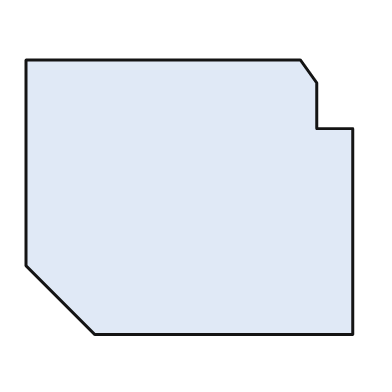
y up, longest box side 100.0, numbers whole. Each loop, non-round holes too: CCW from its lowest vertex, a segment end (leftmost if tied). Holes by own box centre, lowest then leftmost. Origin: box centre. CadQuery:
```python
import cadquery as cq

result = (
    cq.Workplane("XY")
    .moveTo(-29.0, -42.0)
    .lineTo(50.0, -42.0)
    .lineTo(50.0, 21.0)
    .lineTo(39.0, 21.0)
    .lineTo(39.0, 35.0)
    .lineTo(34.0, 42.0)
    .lineTo(-50.0, 42.0)
    .lineTo(-50.0, -21.0)
    .close()
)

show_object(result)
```